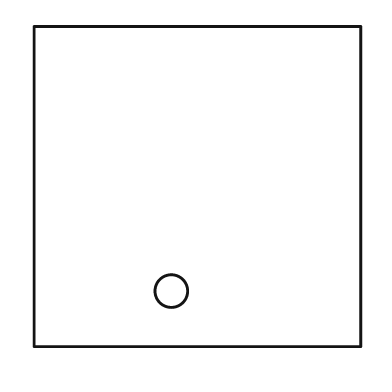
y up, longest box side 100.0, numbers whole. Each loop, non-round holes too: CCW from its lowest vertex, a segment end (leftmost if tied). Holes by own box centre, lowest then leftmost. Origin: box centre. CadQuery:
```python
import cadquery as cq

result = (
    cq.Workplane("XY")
    .moveTo(-50.0, -49.0)
    .lineTo(50.0, -49.0)
    .lineTo(50.0, 49.0)
    .lineTo(-50.0, 49.0)
    .close()
    .moveTo(-8.0, -32.0)
    .circle(5.0)
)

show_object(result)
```